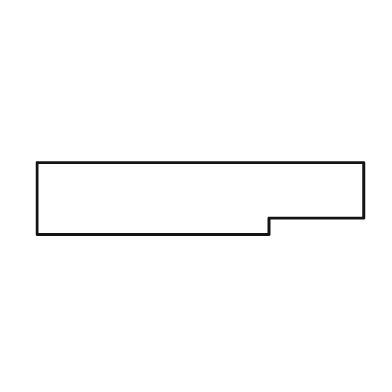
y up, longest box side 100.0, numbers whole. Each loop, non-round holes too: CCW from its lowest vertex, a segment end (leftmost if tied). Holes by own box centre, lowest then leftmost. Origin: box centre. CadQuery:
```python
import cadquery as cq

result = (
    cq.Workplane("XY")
    .moveTo(-50.0, -11.0)
    .lineTo(21.0, -11.0)
    .lineTo(21.0, -6.0)
    .lineTo(50.0, -6.0)
    .lineTo(50.0, 11.0)
    .lineTo(-50.0, 11.0)
    .close()
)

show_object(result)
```